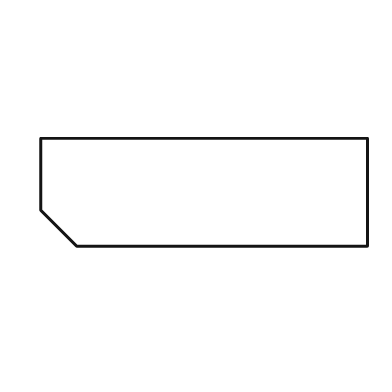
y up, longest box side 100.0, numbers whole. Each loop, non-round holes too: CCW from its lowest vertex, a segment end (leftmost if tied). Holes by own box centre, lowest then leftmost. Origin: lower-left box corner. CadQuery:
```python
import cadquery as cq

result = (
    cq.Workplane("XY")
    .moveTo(11.0, 0.0)
    .lineTo(100.0, 0.0)
    .lineTo(100.0, 33.0)
    .lineTo(0.0, 33.0)
    .lineTo(0.0, 11.0)
    .close()
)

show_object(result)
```